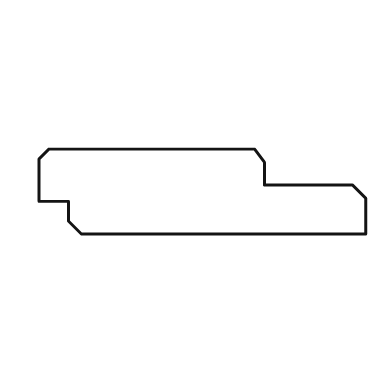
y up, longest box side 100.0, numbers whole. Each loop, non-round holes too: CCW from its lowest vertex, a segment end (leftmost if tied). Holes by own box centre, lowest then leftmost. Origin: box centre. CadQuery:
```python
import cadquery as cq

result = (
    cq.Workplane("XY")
    .moveTo(-37.0, -13.0)
    .lineTo(50.0, -13.0)
    .lineTo(50.0, -2.0)
    .lineTo(46.0, 2.0)
    .lineTo(19.0, 2.0)
    .lineTo(19.0, 9.0)
    .lineTo(16.0, 13.0)
    .lineTo(-47.0, 13.0)
    .lineTo(-50.0, 10.0)
    .lineTo(-50.0, -3.0)
    .lineTo(-41.0, -3.0)
    .lineTo(-41.0, -9.0)
    .close()
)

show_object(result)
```